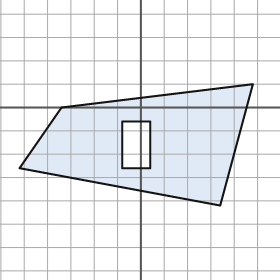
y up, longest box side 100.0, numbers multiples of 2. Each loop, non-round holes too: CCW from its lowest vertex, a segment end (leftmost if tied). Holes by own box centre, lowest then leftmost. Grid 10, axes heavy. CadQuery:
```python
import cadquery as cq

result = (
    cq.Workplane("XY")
    .moveTo(34.0, -42.0)
    .lineTo(48.0, 10.0)
    .lineTo(-34.0, 0.0)
    .lineTo(-52.0, -26.0)
    .close()
    .moveTo(-8.0, -26.0)
    .lineTo(4.0, -26.0)
    .lineTo(4.0, -6.0)
    .lineTo(-8.0, -6.0)
    .close()
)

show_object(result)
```